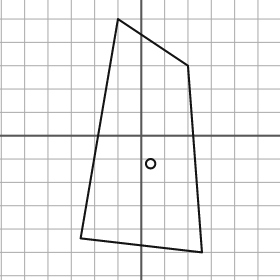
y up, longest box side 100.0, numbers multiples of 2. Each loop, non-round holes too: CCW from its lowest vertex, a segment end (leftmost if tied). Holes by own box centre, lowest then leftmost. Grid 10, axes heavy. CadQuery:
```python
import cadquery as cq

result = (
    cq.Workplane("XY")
    .moveTo(26.0, -50.0)
    .lineTo(20.0, 30.0)
    .lineTo(-10.0, 50.0)
    .lineTo(-26.0, -44.0)
    .close()
    .moveTo(4.0, -12.0)
    .circle(2.0)
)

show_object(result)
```